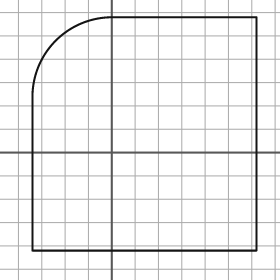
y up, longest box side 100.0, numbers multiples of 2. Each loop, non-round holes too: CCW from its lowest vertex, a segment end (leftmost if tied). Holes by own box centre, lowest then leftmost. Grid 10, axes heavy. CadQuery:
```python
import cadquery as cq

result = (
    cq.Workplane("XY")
    .moveTo(-34.0, -42.0)
    .lineTo(62.0, -42.0)
    .lineTo(62.0, 58.0)
    .lineTo(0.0, 58.0)
    .threePointArc((-24.0, 48.0), (-34.0, 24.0))
    .close()
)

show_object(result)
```